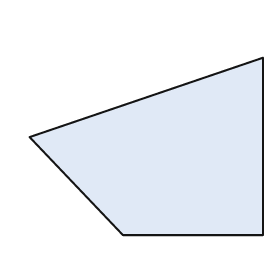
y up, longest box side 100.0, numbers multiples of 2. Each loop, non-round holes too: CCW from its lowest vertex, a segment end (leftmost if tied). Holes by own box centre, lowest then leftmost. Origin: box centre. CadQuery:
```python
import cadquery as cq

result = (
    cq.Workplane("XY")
    .moveTo(-10.0, -38.0)
    .lineTo(50.0, -38.0)
    .lineTo(50.0, 38.0)
    .lineTo(-50.0, 4.0)
    .close()
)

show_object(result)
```